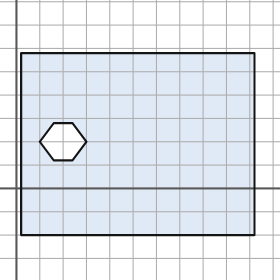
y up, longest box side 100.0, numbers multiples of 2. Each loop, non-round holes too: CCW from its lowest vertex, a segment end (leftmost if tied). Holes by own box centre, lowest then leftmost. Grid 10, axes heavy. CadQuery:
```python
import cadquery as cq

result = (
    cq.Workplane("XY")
    .moveTo(2.0, -20.0)
    .lineTo(102.0, -20.0)
    .lineTo(102.0, 58.0)
    .lineTo(2.0, 58.0)
    .close()
    .moveTo(16.0, 12.0)
    .lineTo(24.0, 12.0)
    .lineTo(30.0, 20.0)
    .lineTo(24.0, 28.0)
    .lineTo(16.0, 28.0)
    .lineTo(10.0, 20.0)
    .close()
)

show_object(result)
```